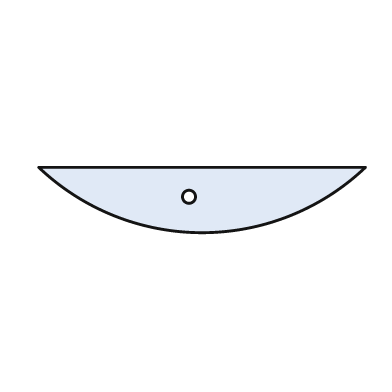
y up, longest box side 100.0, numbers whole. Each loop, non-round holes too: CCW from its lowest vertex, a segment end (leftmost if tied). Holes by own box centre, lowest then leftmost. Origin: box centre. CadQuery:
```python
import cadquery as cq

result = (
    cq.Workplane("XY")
    .moveTo(-50.0, 10.0)
    .threePointArc((0.0, -10.0), (50.0, 10.0))
    .close()
    .moveTo(-4.0, 1.0)
    .circle(2.0)
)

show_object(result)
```